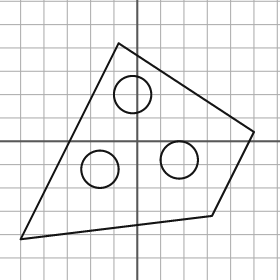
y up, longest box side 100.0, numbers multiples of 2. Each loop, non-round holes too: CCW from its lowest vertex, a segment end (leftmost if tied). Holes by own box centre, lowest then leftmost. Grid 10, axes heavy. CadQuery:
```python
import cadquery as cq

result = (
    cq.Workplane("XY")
    .moveTo(-50.0, -42.0)
    .lineTo(32.0, -32.0)
    .lineTo(50.0, 4.0)
    .lineTo(-8.0, 42.0)
    .close()
    .moveTo(-16.0, -12.0)
    .circle(8.0)
    .moveTo(18.0, -8.0)
    .circle(8.0)
    .moveTo(-2.0, 20.0)
    .circle(8.0)
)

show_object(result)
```